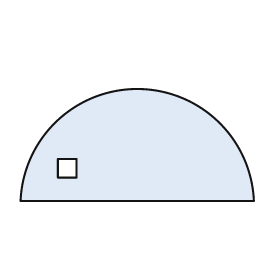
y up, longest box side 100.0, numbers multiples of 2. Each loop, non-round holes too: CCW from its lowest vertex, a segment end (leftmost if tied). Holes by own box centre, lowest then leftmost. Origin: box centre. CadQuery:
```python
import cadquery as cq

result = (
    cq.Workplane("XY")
    .moveTo(-50.0, -24.0)
    .lineTo(50.0, -24.0)
    .threePointArc((0.0, 24.0), (-50.0, -24.0))
    .close()
    .moveTo(-34.0, -14.0)
    .lineTo(-26.0, -14.0)
    .lineTo(-26.0, -6.0)
    .lineTo(-34.0, -6.0)
    .close()
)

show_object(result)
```